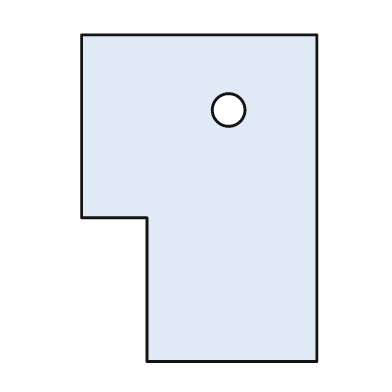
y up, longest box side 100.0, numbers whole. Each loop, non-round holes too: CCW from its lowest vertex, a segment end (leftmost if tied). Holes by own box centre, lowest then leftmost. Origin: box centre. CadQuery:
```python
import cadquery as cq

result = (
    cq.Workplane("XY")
    .moveTo(-16.0, -50.0)
    .lineTo(36.0, -50.0)
    .lineTo(36.0, 50.0)
    .lineTo(-36.0, 50.0)
    .lineTo(-36.0, -6.0)
    .lineTo(-16.0, -6.0)
    .close()
    .moveTo(9.0, 27.0)
    .circle(5.0)
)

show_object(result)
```